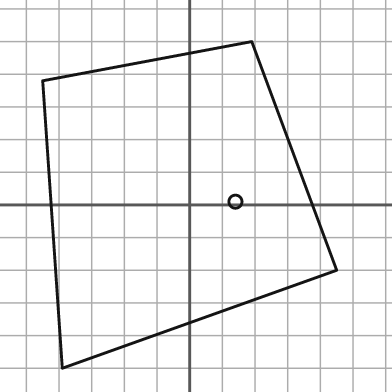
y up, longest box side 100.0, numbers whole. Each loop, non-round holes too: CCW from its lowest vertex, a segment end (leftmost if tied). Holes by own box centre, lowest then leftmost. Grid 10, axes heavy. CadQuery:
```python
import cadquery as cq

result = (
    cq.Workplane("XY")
    .moveTo(-39.0, -50.0)
    .lineTo(45.0, -20.0)
    .lineTo(19.0, 50.0)
    .lineTo(-45.0, 38.0)
    .close()
    .moveTo(14.0, 1.0)
    .circle(2.0)
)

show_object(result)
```